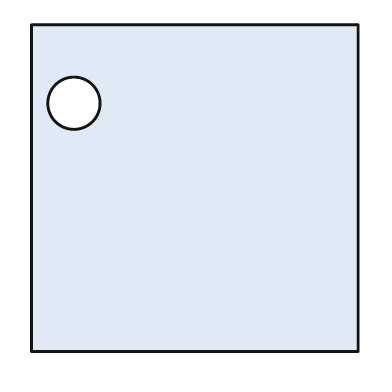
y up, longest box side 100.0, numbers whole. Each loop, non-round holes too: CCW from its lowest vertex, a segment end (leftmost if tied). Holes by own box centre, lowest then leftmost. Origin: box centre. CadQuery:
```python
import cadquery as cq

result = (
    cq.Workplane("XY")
    .moveTo(-50.0, -50.0)
    .lineTo(50.0, -50.0)
    .lineTo(50.0, 50.0)
    .lineTo(-50.0, 50.0)
    .close()
    .moveTo(-37.0, 26.0)
    .circle(8.0)
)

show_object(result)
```